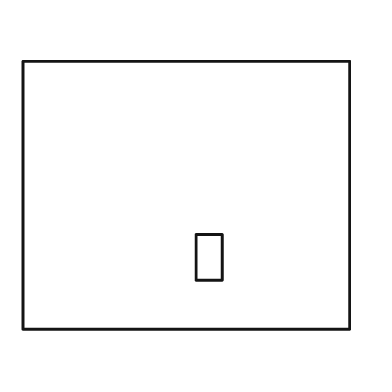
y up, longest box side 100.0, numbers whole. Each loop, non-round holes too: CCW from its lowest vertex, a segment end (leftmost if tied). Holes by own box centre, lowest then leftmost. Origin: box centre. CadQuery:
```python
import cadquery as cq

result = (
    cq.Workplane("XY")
    .moveTo(-50.0, -41.0)
    .lineTo(50.0, -41.0)
    .lineTo(50.0, 41.0)
    .lineTo(-50.0, 41.0)
    .close()
    .moveTo(3.0, -26.0)
    .lineTo(11.0, -26.0)
    .lineTo(11.0, -12.0)
    .lineTo(3.0, -12.0)
    .close()
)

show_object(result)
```